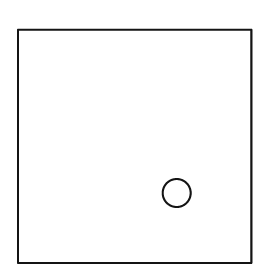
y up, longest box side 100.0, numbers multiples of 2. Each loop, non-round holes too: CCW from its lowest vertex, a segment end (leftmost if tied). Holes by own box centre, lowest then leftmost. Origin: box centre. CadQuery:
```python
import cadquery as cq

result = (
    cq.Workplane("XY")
    .moveTo(-50.0, -50.0)
    .lineTo(50.0, -50.0)
    .lineTo(50.0, 50.0)
    .lineTo(-50.0, 50.0)
    .close()
    .moveTo(18.0, -20.0)
    .circle(6.0)
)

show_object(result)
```